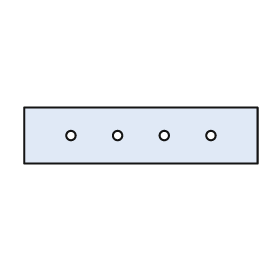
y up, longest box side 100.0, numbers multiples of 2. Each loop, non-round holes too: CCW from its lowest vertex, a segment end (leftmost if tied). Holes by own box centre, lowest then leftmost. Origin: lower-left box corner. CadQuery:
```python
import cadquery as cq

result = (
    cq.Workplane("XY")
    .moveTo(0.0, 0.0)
    .lineTo(100.0, 0.0)
    .lineTo(100.0, 24.0)
    .lineTo(0.0, 24.0)
    .close()
    .moveTo(20.0, 12.0)
    .circle(2.0)
    .moveTo(40.0, 12.0)
    .circle(2.0)
    .moveTo(60.0, 12.0)
    .circle(2.0)
    .moveTo(80.0, 12.0)
    .circle(2.0)
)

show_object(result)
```